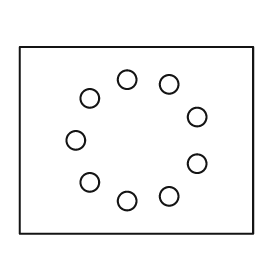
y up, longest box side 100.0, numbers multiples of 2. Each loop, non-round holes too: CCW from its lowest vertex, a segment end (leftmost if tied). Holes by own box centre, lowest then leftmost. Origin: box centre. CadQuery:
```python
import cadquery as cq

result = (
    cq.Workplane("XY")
    .moveTo(-50.0, -40.0)
    .lineTo(50.0, -40.0)
    .lineTo(50.0, 40.0)
    .lineTo(-50.0, 40.0)
    .close()
    .moveTo(-4.0, -26.0)
    .circle(4.0)
    .moveTo(14.0, -24.0)
    .circle(4.0)
    .moveTo(-20.0, -18.0)
    .circle(4.0)
    .moveTo(26.0, -10.0)
    .circle(4.0)
    .moveTo(-26.0, 0.0)
    .circle(4.0)
    .moveTo(26.0, 10.0)
    .circle(4.0)
    .moveTo(-20.0, 18.0)
    .circle(4.0)
    .moveTo(14.0, 24.0)
    .circle(4.0)
    .moveTo(-4.0, 26.0)
    .circle(4.0)
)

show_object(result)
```